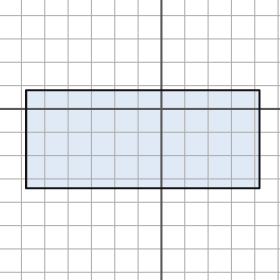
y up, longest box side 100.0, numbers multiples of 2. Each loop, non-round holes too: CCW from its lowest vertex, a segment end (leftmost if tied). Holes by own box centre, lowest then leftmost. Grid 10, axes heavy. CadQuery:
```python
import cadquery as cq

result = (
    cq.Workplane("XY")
    .moveTo(-58.0, -34.0)
    .lineTo(42.0, -34.0)
    .lineTo(42.0, 8.0)
    .lineTo(-58.0, 8.0)
    .close()
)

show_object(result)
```